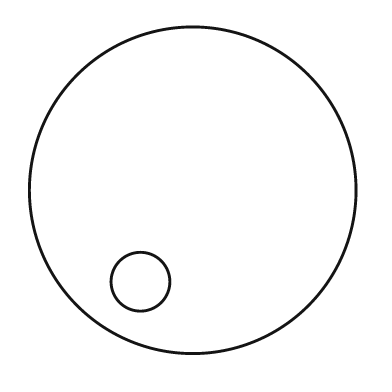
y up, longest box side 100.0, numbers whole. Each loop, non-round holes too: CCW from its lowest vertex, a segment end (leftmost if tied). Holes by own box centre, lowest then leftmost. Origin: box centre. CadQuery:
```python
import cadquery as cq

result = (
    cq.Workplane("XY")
    .moveTo(0.0, 0.0)
    .circle(50.0)
    .moveTo(-16.0, -28.0)
    .circle(9.0)
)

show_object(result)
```